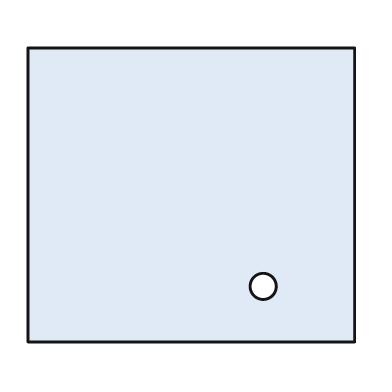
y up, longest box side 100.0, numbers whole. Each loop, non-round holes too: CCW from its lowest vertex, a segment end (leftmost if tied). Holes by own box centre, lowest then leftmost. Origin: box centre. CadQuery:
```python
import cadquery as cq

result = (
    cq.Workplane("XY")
    .moveTo(-50.0, -45.0)
    .lineTo(50.0, -45.0)
    .lineTo(50.0, 45.0)
    .lineTo(-50.0, 45.0)
    .close()
    .moveTo(22.0, -28.0)
    .circle(4.0)
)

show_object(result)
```